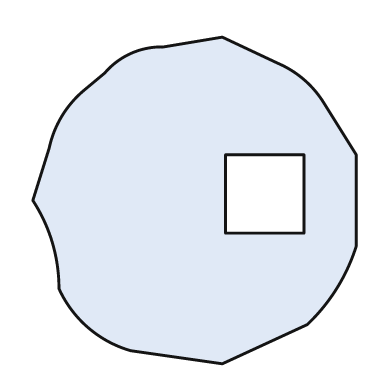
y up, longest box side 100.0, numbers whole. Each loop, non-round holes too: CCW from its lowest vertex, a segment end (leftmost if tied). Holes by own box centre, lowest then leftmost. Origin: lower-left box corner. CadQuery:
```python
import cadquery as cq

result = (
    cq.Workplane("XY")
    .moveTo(58.0, 0.0)
    .lineTo(84.0, 12.0)
    .threePointArc((93.0, 23.0), (99.0, 36.0))
    .lineTo(99.0, 64.0)
    .lineTo(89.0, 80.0)
    .threePointArc((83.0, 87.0), (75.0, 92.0))
    .lineTo(58.0, 100.0)
    .lineTo(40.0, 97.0)
    .threePointArc((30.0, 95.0), (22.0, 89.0))
    .lineTo(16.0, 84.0)
    .threePointArc((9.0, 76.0), (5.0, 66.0))
    .lineTo(0.0, 50.0)
    .threePointArc((6.0, 37.0), (8.0, 23.0))
    .threePointArc((17.0, 11.0), (30.0, 4.0))
    .close()
    .moveTo(59.0, 40.0)
    .lineTo(83.0, 40.0)
    .lineTo(83.0, 64.0)
    .lineTo(59.0, 64.0)
    .close()
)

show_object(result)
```